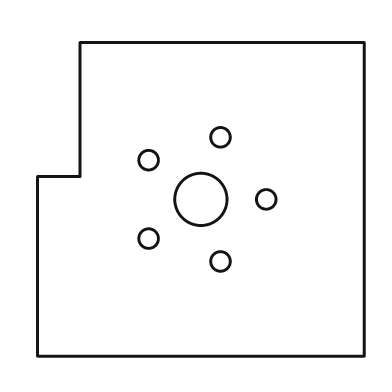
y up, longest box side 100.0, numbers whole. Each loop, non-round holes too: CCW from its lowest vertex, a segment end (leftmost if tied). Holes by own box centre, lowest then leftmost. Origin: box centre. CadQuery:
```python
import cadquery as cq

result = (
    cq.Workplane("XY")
    .moveTo(-50.0, -48.0)
    .lineTo(50.0, -48.0)
    .lineTo(50.0, 48.0)
    .lineTo(-37.0, 48.0)
    .lineTo(-37.0, 7.0)
    .lineTo(-50.0, 7.0)
    .close()
    .moveTo(6.0, -19.0)
    .circle(3.0)
    .moveTo(-16.0, -12.0)
    .circle(3.0)
    .moveTo(0.0, 0.0)
    .circle(8.0)
    .moveTo(20.0, 0.0)
    .circle(3.0)
    .moveTo(-16.0, 12.0)
    .circle(3.0)
    .moveTo(6.0, 19.0)
    .circle(3.0)
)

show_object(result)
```